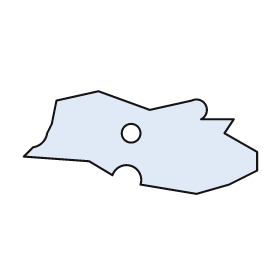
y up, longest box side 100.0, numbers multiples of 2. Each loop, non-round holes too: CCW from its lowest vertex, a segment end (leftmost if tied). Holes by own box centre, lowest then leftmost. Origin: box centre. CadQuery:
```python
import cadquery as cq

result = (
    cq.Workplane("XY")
    .moveTo(24.0, -22.0)
    .lineTo(38.0, -18.0)
    .lineTo(50.0, -12.0)
    .lineTo(50.0, -4.0)
    .lineTo(36.0, 4.0)
    .lineTo(40.0, 10.0)
    .lineTo(26.0, 10.0)
    .threePointArc((28.0, 16.0), (22.0, 18.0))
    .lineTo(4.0, 14.0)
    .lineTo(-18.0, 22.0)
    .lineTo(-36.0, 18.0)
    .lineTo(-38.0, 8.0)
    .lineTo(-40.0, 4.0)
    .threePointArc((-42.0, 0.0), (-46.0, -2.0))
    .lineTo(-50.0, -6.0)
    .lineTo(-22.0, -8.0)
    .lineTo(-12.0, -14.0)
    .threePointArc((-4.0, -10.0), (0.0, -18.0))
    .close()
    .moveTo(-4.0, 4.0)
    .circle(4.0)
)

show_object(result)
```